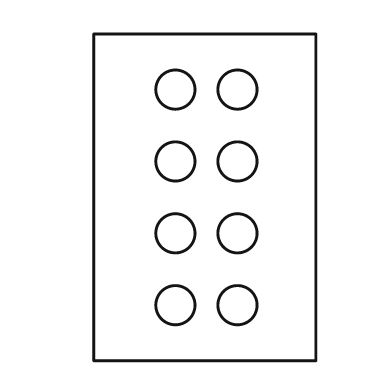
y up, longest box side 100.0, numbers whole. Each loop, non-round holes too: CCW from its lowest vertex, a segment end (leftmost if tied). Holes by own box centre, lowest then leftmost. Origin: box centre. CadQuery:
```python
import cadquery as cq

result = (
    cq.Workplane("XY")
    .moveTo(-34.0, -50.0)
    .lineTo(34.0, -50.0)
    .lineTo(34.0, 50.0)
    .lineTo(-34.0, 50.0)
    .close()
    .moveTo(-9.0, -33.0)
    .circle(6.0)
    .moveTo(10.0, -33.0)
    .circle(6.0)
    .moveTo(-9.0, -11.0)
    .circle(6.0)
    .moveTo(10.0, -11.0)
    .circle(6.0)
    .moveTo(-9.0, 11.0)
    .circle(6.0)
    .moveTo(10.0, 11.0)
    .circle(6.0)
    .moveTo(-9.0, 33.0)
    .circle(6.0)
    .moveTo(10.0, 33.0)
    .circle(6.0)
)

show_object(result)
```